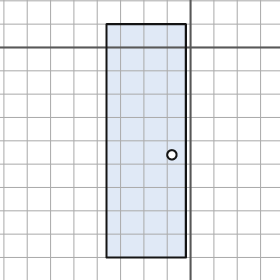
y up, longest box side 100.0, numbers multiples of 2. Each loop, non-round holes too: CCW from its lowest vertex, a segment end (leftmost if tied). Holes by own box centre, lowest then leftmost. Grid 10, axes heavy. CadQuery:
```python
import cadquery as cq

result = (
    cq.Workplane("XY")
    .moveTo(-36.0, -90.0)
    .lineTo(-2.0, -90.0)
    .lineTo(-2.0, 10.0)
    .lineTo(-36.0, 10.0)
    .close()
    .moveTo(-8.0, -46.0)
    .circle(2.0)
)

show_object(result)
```